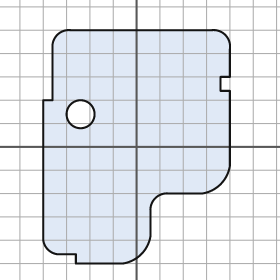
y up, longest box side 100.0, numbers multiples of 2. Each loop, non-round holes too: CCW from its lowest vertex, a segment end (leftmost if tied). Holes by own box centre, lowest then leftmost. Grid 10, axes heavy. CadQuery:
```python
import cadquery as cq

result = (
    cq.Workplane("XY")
    .moveTo(-26.0, -50.0)
    .lineTo(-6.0, -50.0)
    .threePointArc((2.0, -46.0), (6.0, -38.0))
    .lineTo(6.0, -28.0)
    .threePointArc((8.0, -22.0), (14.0, -20.0))
    .lineTo(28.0, -20.0)
    .threePointArc((36.0, -16.0), (40.0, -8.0))
    .lineTo(40.0, 24.0)
    .lineTo(36.0, 24.0)
    .lineTo(36.0, 30.0)
    .lineTo(40.0, 30.0)
    .lineTo(40.0, 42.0)
    .threePointArc((38.0, 48.0), (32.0, 50.0))
    .lineTo(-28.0, 50.0)
    .threePointArc((-34.0, 48.0), (-36.0, 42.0))
    .lineTo(-36.0, 20.0)
    .lineTo(-40.0, 20.0)
    .lineTo(-40.0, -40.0)
    .threePointArc((-38.0, -44.0), (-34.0, -46.0))
    .lineTo(-26.0, -46.0)
    .close()
    .moveTo(-24.0, 14.0)
    .circle(6.0)
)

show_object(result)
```